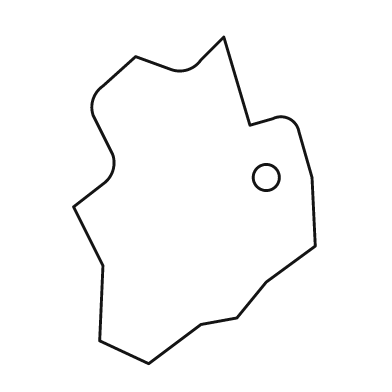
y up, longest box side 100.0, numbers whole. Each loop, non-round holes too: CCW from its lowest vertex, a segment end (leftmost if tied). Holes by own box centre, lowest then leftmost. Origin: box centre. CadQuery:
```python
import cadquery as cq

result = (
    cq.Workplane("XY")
    .moveTo(-14.0, -50.0)
    .lineTo(2.0, -38.0)
    .lineTo(13.0, -36.0)
    .lineTo(22.0, -25.0)
    .lineTo(37.0, -14.0)
    .lineTo(36.0, 7.0)
    .lineTo(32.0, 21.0)
    .threePointArc((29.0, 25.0), (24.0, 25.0))
    .lineTo(17.0, 23.0)
    .lineTo(9.0, 50.0)
    .lineTo(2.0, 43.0)
    .threePointArc((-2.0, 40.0), (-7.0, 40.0))
    .lineTo(-18.0, 44.0)
    .lineTo(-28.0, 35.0)
    .threePointArc((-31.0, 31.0), (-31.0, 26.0))
    .lineTo(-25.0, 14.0)
    .threePointArc((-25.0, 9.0), (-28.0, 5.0))
    .lineTo(-37.0, -2.0)
    .lineTo(-28.0, -20.0)
    .lineTo(-29.0, -43.0)
    .close()
    .moveTo(22.0, 7.0)
    .circle(4.0)
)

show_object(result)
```